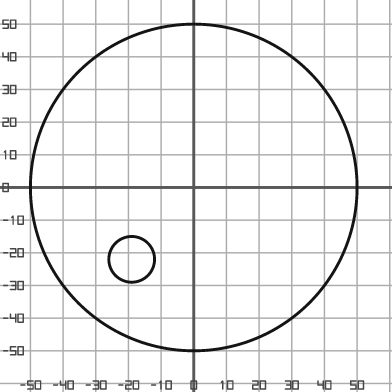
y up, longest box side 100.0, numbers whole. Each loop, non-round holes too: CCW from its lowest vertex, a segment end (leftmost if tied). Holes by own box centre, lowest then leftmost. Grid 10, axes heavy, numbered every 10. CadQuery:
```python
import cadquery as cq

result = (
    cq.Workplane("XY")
    .moveTo(0.0, 0.0)
    .circle(50.0)
    .moveTo(-19.0, -22.0)
    .circle(7.0)
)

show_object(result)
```